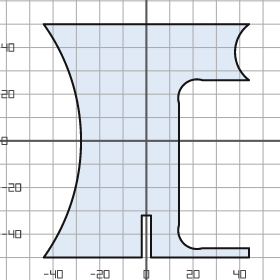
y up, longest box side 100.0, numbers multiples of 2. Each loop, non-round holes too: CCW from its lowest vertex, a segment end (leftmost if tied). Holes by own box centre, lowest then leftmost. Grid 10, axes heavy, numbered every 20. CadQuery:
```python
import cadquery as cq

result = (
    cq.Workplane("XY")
    .moveTo(-44.0, -50.0)
    .lineTo(-2.0, -50.0)
    .lineTo(-2.0, -32.0)
    .lineTo(2.0, -32.0)
    .lineTo(2.0, -50.0)
    .lineTo(44.0, -50.0)
    .lineTo(44.0, -46.0)
    .lineTo(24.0, -46.0)
    .threePointArc((16.0, -44.0), (14.0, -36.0))
    .lineTo(14.0, 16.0)
    .threePointArc((16.0, 24.0), (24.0, 26.0))
    .lineTo(44.0, 26.0)
    .threePointArc((38.0, 38.0), (44.0, 50.0))
    .lineTo(-44.0, 50.0)
    .threePointArc((-28.0, 0.0), (-44.0, -50.0))
    .close()
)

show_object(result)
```